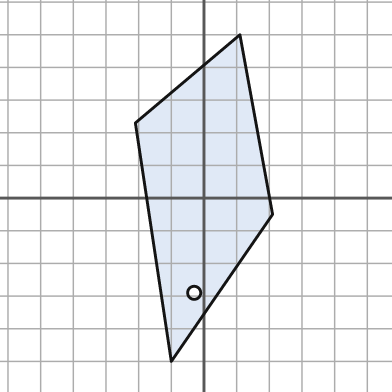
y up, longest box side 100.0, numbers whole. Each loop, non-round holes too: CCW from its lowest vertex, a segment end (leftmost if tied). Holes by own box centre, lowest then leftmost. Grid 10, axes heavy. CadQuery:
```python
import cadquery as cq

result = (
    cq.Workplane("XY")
    .moveTo(-10.0, -50.0)
    .lineTo(21.0, -5.0)
    .lineTo(11.0, 50.0)
    .lineTo(-21.0, 23.0)
    .close()
    .moveTo(-3.0, -29.0)
    .circle(2.0)
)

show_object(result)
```